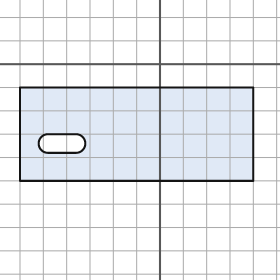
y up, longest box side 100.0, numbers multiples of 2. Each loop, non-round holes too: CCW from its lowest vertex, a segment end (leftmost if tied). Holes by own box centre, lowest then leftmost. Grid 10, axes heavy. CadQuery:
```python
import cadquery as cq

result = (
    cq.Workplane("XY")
    .moveTo(-60.0, -50.0)
    .lineTo(40.0, -50.0)
    .lineTo(40.0, -10.0)
    .lineTo(-60.0, -10.0)
    .close()
    .moveTo(-48.0, -38.0)
    .lineTo(-36.0, -38.0)
    .threePointArc((-32.0, -34.0), (-36.0, -30.0))
    .lineTo(-48.0, -30.0)
    .threePointArc((-52.0, -34.0), (-48.0, -38.0))
    .close()
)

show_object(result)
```